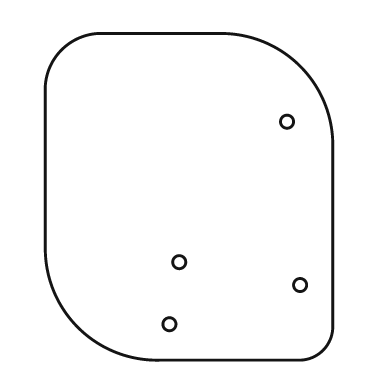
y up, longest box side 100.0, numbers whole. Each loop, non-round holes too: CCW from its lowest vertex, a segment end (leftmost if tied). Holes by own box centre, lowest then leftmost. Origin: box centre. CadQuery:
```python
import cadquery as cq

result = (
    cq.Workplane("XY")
    .moveTo(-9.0, -50.0)
    .lineTo(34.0, -50.0)
    .threePointArc((41.0, -47.0), (44.0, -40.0))
    .lineTo(44.0, 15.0)
    .threePointArc((34.0, 40.0), (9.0, 50.0))
    .lineTo(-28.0, 50.0)
    .threePointArc((-39.0, 45.0), (-44.0, 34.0))
    .lineTo(-44.0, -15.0)
    .threePointArc((-34.0, -40.0), (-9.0, -50.0))
    .close()
    .moveTo(-6.0, -39.0)
    .circle(2.0)
    .moveTo(34.0, -27.0)
    .circle(2.0)
    .moveTo(-3.0, -20.0)
    .circle(2.0)
    .moveTo(30.0, 23.0)
    .circle(2.0)
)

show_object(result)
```